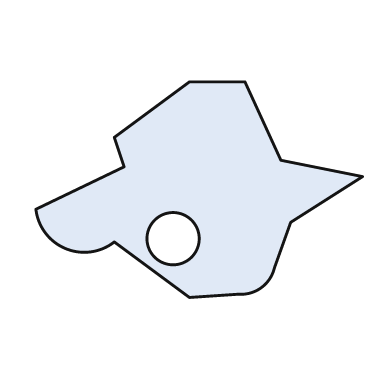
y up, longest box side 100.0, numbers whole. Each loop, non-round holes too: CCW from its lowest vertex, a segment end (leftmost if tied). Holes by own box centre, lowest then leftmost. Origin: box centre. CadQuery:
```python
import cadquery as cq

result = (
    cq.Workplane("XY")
    .moveTo(-3.0, -33.0)
    .lineTo(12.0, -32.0)
    .threePointArc((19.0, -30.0), (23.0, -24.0))
    .lineTo(28.0, -10.0)
    .lineTo(50.0, 4.0)
    .lineTo(25.0, 9.0)
    .lineTo(14.0, 33.0)
    .lineTo(-3.0, 33.0)
    .lineTo(-26.0, 16.0)
    .lineTo(-23.0, 7.0)
    .lineTo(-50.0, -6.0)
    .threePointArc((-41.0, -18.0), (-26.0, -16.0))
    .close()
    .moveTo(-8.0, -15.0)
    .circle(8.0)
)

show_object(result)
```